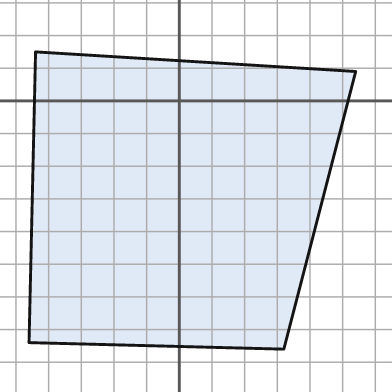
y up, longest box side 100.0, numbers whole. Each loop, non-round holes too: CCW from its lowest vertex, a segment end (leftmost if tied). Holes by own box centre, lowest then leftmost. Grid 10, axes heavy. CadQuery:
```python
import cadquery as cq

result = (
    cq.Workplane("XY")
    .moveTo(32.0, -76.0)
    .lineTo(54.0, 9.0)
    .lineTo(-44.0, 15.0)
    .lineTo(-46.0, -74.0)
    .close()
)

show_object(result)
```